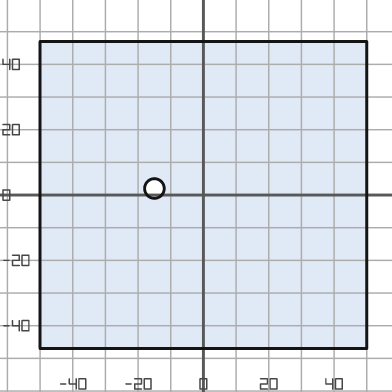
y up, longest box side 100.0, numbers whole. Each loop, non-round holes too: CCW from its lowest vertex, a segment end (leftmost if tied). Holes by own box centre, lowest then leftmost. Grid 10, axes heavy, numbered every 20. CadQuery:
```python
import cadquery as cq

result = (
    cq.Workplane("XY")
    .moveTo(-50.0, -47.0)
    .lineTo(50.0, -47.0)
    .lineTo(50.0, 47.0)
    .lineTo(-50.0, 47.0)
    .close()
    .moveTo(-15.0, 2.0)
    .circle(3.0)
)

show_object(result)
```